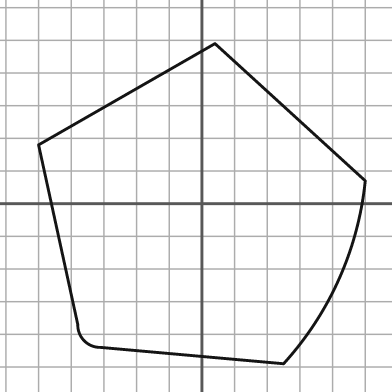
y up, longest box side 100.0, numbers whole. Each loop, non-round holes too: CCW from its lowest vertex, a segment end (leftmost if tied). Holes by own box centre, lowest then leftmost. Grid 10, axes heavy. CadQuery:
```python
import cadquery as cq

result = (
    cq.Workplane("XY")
    .moveTo(25.0, -49.0)
    .threePointArc((42.0, -23.0), (50.0, 7.0))
    .lineTo(4.0, 49.0)
    .lineTo(-50.0, 18.0)
    .lineTo(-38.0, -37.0)
    .threePointArc((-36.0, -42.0), (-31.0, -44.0))
    .close()
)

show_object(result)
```